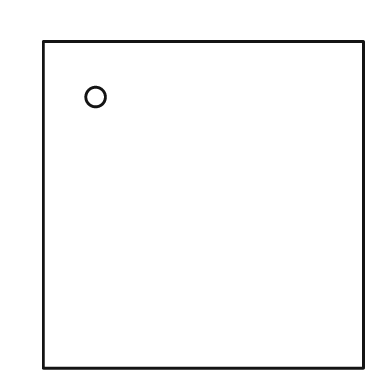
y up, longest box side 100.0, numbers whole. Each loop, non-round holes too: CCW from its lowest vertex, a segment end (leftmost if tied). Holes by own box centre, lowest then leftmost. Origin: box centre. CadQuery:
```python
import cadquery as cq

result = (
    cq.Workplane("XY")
    .moveTo(-49.0, -50.0)
    .lineTo(49.0, -50.0)
    .lineTo(49.0, 50.0)
    .lineTo(-49.0, 50.0)
    .close()
    .moveTo(-33.0, 33.0)
    .circle(3.0)
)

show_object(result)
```